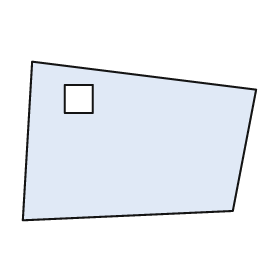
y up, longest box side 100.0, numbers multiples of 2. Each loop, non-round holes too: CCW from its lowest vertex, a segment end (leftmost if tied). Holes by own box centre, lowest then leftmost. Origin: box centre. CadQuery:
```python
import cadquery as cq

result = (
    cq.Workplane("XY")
    .moveTo(-50.0, -34.0)
    .lineTo(40.0, -30.0)
    .lineTo(50.0, 22.0)
    .lineTo(-46.0, 34.0)
    .close()
    .moveTo(-32.0, 12.0)
    .lineTo(-20.0, 12.0)
    .lineTo(-20.0, 24.0)
    .lineTo(-32.0, 24.0)
    .close()
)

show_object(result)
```